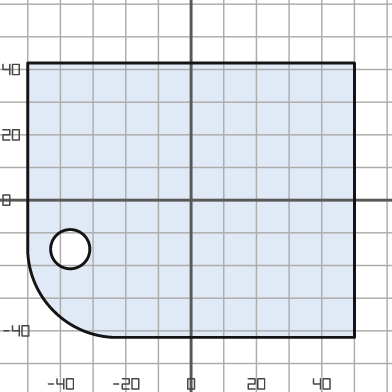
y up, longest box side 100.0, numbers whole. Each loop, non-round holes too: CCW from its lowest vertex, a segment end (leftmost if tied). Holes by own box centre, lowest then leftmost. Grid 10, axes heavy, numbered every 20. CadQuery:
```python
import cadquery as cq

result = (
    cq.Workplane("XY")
    .moveTo(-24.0, -42.0)
    .lineTo(50.0, -42.0)
    .lineTo(50.0, 42.0)
    .lineTo(-50.0, 42.0)
    .lineTo(-50.0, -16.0)
    .threePointArc((-42.0, -34.0), (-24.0, -42.0))
    .close()
    .moveTo(-37.0, -15.0)
    .circle(6.0)
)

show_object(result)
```